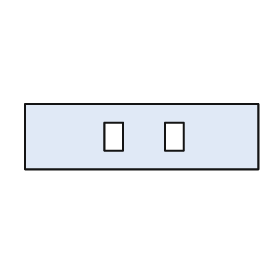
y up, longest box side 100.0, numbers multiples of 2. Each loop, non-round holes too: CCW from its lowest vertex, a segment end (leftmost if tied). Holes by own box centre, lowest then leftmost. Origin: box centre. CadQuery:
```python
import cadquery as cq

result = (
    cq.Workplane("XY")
    .moveTo(-50.0, -14.0)
    .lineTo(50.0, -14.0)
    .lineTo(50.0, 14.0)
    .lineTo(-50.0, 14.0)
    .close()
    .moveTo(-16.0, -6.0)
    .lineTo(-8.0, -6.0)
    .lineTo(-8.0, 6.0)
    .lineTo(-16.0, 6.0)
    .close()
    .moveTo(10.0, -6.0)
    .lineTo(18.0, -6.0)
    .lineTo(18.0, 6.0)
    .lineTo(10.0, 6.0)
    .close()
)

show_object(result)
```